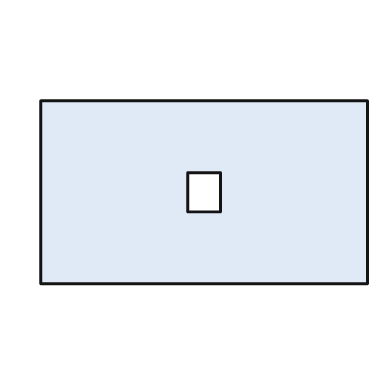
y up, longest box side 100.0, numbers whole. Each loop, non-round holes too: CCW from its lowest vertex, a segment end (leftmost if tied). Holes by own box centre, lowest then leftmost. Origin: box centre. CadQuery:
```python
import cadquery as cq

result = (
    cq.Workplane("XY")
    .moveTo(-50.0, -28.0)
    .lineTo(50.0, -28.0)
    .lineTo(50.0, 28.0)
    .lineTo(-50.0, 28.0)
    .close()
    .moveTo(-5.0, -6.0)
    .lineTo(5.0, -6.0)
    .lineTo(5.0, 6.0)
    .lineTo(-5.0, 6.0)
    .close()
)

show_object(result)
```